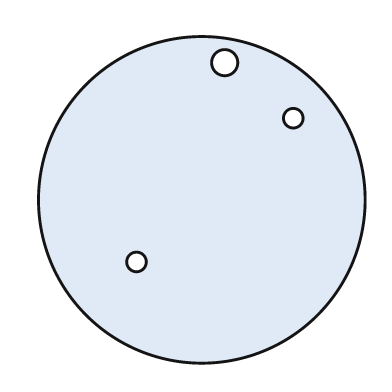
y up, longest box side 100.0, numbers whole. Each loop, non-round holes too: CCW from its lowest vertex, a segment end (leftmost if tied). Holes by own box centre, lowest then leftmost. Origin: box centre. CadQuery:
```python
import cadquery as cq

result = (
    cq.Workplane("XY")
    .moveTo(0.0, 0.0)
    .circle(50.0)
    .moveTo(-20.0, -19.0)
    .circle(3.0)
    .moveTo(28.0, 25.0)
    .circle(3.0)
    .moveTo(7.0, 42.0)
    .circle(4.0)
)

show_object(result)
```